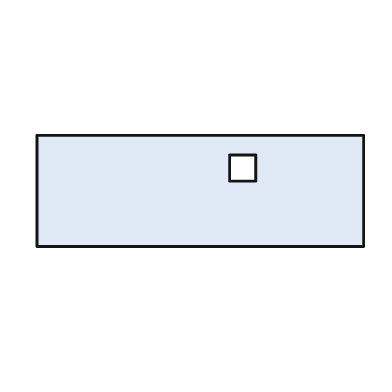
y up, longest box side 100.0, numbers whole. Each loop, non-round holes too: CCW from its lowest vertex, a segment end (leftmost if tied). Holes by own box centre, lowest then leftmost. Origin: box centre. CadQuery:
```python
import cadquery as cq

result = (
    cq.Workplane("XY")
    .moveTo(-50.0, -17.0)
    .lineTo(50.0, -17.0)
    .lineTo(50.0, 17.0)
    .lineTo(-50.0, 17.0)
    .close()
    .moveTo(9.0, 3.0)
    .lineTo(17.0, 3.0)
    .lineTo(17.0, 11.0)
    .lineTo(9.0, 11.0)
    .close()
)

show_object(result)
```